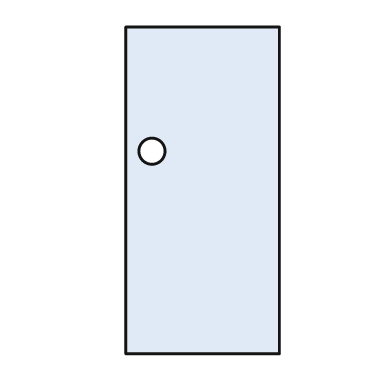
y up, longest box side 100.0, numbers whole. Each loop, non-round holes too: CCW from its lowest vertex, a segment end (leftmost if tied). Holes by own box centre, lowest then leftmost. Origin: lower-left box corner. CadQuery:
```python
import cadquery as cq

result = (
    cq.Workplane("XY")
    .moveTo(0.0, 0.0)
    .lineTo(47.0, 0.0)
    .lineTo(47.0, 100.0)
    .lineTo(0.0, 100.0)
    .close()
    .moveTo(8.0, 62.0)
    .circle(4.0)
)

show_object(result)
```